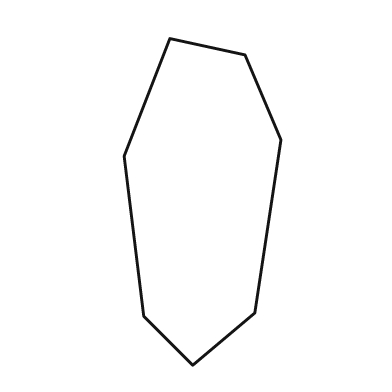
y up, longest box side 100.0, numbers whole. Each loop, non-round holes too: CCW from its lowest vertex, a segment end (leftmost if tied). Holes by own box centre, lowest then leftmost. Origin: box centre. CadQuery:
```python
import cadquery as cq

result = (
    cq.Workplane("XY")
    .moveTo(-3.0, -50.0)
    .lineTo(16.0, -34.0)
    .lineTo(24.0, 19.0)
    .lineTo(13.0, 45.0)
    .lineTo(-10.0, 50.0)
    .lineTo(-24.0, 14.0)
    .lineTo(-18.0, -35.0)
    .close()
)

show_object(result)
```